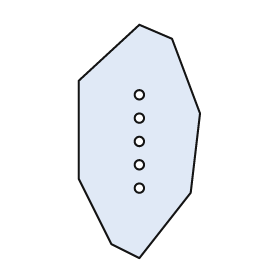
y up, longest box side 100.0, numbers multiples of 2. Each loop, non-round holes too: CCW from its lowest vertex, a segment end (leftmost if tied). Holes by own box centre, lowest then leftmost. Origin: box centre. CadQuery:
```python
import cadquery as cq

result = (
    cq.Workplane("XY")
    .moveTo(0.0, -50.0)
    .lineTo(22.0, -22.0)
    .lineTo(26.0, 12.0)
    .lineTo(14.0, 44.0)
    .lineTo(0.0, 50.0)
    .lineTo(-26.0, 26.0)
    .lineTo(-26.0, -16.0)
    .lineTo(-12.0, -44.0)
    .close()
    .moveTo(0.0, -20.0)
    .circle(2.0)
    .moveTo(0.0, -10.0)
    .circle(2.0)
    .moveTo(0.0, 0.0)
    .circle(2.0)
    .moveTo(0.0, 10.0)
    .circle(2.0)
    .moveTo(0.0, 20.0)
    .circle(2.0)
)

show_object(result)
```